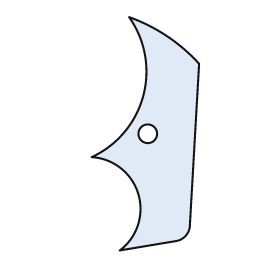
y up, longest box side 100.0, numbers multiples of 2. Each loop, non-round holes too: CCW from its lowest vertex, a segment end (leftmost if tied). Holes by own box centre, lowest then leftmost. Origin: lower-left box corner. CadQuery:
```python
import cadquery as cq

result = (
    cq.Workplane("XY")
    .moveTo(12.0, 0.0)
    .lineTo(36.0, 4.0)
    .threePointArc((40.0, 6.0), (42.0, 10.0))
    .lineTo(46.0, 80.0)
    .threePointArc((32.0, 92.0), (16.0, 100.0))
    .threePointArc((22.0, 66.0), (0.0, 40.0))
    .threePointArc((20.0, 24.0), (12.0, 0.0))
    .close()
    .moveTo(24.0, 50.0)
    .circle(4.0)
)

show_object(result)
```